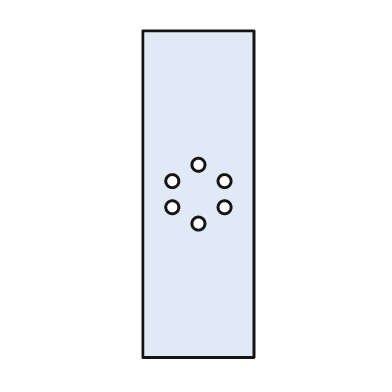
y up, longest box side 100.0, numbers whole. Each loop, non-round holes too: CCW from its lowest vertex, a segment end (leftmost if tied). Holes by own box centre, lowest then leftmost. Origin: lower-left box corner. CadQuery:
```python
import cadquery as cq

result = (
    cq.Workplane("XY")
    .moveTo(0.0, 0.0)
    .lineTo(34.0, 0.0)
    .lineTo(34.0, 100.0)
    .lineTo(0.0, 100.0)
    .close()
    .moveTo(17.0, 41.0)
    .circle(2.0)
    .moveTo(9.0, 46.0)
    .circle(2.0)
    .moveTo(25.0, 46.0)
    .circle(2.0)
    .moveTo(9.0, 54.0)
    .circle(2.0)
    .moveTo(25.0, 54.0)
    .circle(2.0)
    .moveTo(17.0, 59.0)
    .circle(2.0)
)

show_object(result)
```